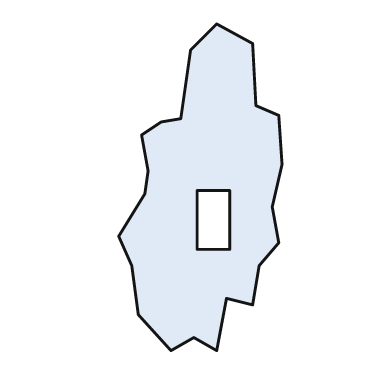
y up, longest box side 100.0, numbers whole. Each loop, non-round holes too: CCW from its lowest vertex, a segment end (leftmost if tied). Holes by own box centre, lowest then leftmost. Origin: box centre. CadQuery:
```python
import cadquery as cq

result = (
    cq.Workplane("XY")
    .moveTo(-9.0, -50.0)
    .lineTo(-2.0, -46.0)
    .lineTo(5.0, -50.0)
    .lineTo(8.0, -34.0)
    .lineTo(16.0, -36.0)
    .lineTo(18.0, -24.0)
    .lineTo(24.0, -17.0)
    .lineTo(22.0, -6.0)
    .lineTo(25.0, 7.0)
    .lineTo(24.0, 22.0)
    .lineTo(17.0, 25.0)
    .lineTo(16.0, 44.0)
    .lineTo(5.0, 50.0)
    .lineTo(-3.0, 42.0)
    .lineTo(-6.0, 21.0)
    .lineTo(-12.0, 20.0)
    .lineTo(-18.0, 16.0)
    .lineTo(-16.0, 5.0)
    .lineTo(-17.0, -2.0)
    .lineTo(-25.0, -15.0)
    .lineTo(-21.0, -24.0)
    .lineTo(-19.0, -39.0)
    .close()
    .moveTo(-1.0, -19.0)
    .lineTo(9.0, -19.0)
    .lineTo(9.0, -1.0)
    .lineTo(-1.0, -1.0)
    .close()
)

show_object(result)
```